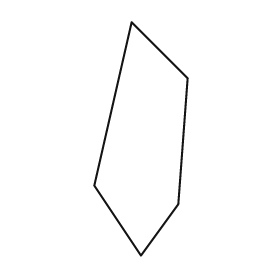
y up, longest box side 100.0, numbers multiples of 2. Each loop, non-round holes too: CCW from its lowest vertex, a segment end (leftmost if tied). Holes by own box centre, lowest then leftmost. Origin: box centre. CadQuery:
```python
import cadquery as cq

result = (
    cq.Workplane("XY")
    .moveTo(0.0, -50.0)
    .lineTo(16.0, -28.0)
    .lineTo(20.0, 26.0)
    .lineTo(-4.0, 50.0)
    .lineTo(-20.0, -20.0)
    .close()
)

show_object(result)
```